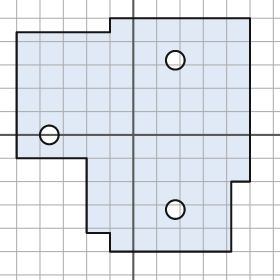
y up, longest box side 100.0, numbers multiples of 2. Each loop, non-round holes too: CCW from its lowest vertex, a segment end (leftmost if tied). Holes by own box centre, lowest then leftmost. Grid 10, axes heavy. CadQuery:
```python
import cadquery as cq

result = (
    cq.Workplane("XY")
    .moveTo(-10.0, -50.0)
    .lineTo(42.0, -50.0)
    .lineTo(42.0, -20.0)
    .lineTo(50.0, -20.0)
    .lineTo(50.0, 50.0)
    .lineTo(-10.0, 50.0)
    .lineTo(-10.0, 44.0)
    .lineTo(-50.0, 44.0)
    .lineTo(-50.0, -10.0)
    .lineTo(-20.0, -10.0)
    .lineTo(-20.0, -42.0)
    .lineTo(-10.0, -42.0)
    .close()
    .moveTo(18.0, -32.0)
    .circle(4.0)
    .moveTo(-36.0, 0.0)
    .circle(4.0)
    .moveTo(18.0, 32.0)
    .circle(4.0)
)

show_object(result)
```